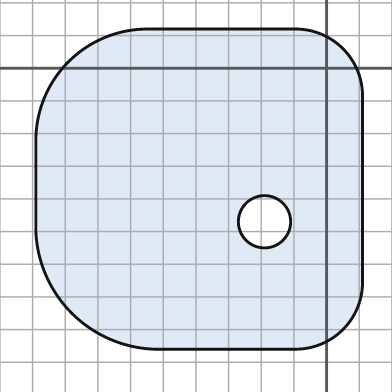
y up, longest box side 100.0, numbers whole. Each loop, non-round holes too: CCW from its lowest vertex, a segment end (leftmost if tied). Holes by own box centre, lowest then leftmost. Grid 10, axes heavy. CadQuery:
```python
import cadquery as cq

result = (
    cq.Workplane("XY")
    .moveTo(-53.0, -86.0)
    .lineTo(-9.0, -86.0)
    .threePointArc((5.0, -80.0), (11.0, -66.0))
    .lineTo(11.0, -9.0)
    .threePointArc((5.0, 6.0), (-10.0, 12.0))
    .lineTo(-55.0, 12.0)
    .threePointArc((-79.0, 2.0), (-89.0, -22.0))
    .lineTo(-89.0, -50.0)
    .threePointArc((-78.0, -75.0), (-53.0, -86.0))
    .close()
    .moveTo(-19.0, -47.0)
    .circle(8.0)
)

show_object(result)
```